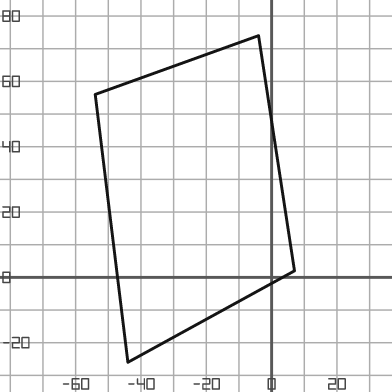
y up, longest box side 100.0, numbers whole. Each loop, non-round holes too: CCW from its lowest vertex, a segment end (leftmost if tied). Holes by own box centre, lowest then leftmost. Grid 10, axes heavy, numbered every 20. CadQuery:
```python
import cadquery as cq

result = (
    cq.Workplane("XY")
    .moveTo(-44.0, -26.0)
    .lineTo(7.0, 2.0)
    .lineTo(-4.0, 74.0)
    .lineTo(-54.0, 56.0)
    .close()
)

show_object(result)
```